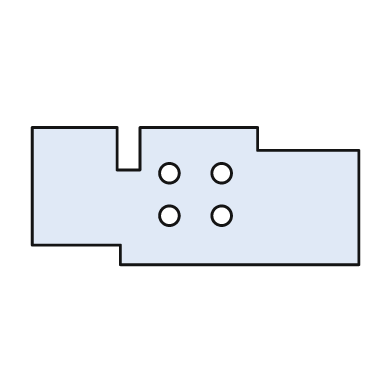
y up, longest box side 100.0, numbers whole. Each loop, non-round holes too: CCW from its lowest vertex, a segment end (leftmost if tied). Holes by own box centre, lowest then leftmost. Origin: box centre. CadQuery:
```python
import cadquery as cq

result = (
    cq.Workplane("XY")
    .moveTo(-23.0, -21.0)
    .lineTo(50.0, -21.0)
    .lineTo(50.0, 14.0)
    .lineTo(19.0, 14.0)
    .lineTo(19.0, 21.0)
    .lineTo(-17.0, 21.0)
    .lineTo(-17.0, 8.0)
    .lineTo(-24.0, 8.0)
    .lineTo(-24.0, 21.0)
    .lineTo(-50.0, 21.0)
    .lineTo(-50.0, -15.0)
    .lineTo(-23.0, -15.0)
    .close()
    .moveTo(-8.0, -6.0)
    .circle(3.0)
    .moveTo(8.0, -6.0)
    .circle(3.0)
    .moveTo(-8.0, 7.0)
    .circle(3.0)
    .moveTo(8.0, 7.0)
    .circle(3.0)
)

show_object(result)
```